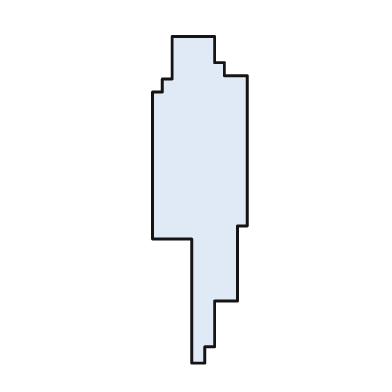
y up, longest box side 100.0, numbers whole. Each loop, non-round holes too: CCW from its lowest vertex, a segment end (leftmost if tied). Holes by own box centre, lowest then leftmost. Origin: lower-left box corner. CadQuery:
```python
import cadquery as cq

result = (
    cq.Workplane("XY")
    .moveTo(12.0, 0.0)
    .lineTo(16.0, 0.0)
    .lineTo(16.0, 5.0)
    .lineTo(19.0, 5.0)
    .lineTo(19.0, 19.0)
    .lineTo(26.0, 19.0)
    .lineTo(26.0, 42.0)
    .lineTo(29.0, 42.0)
    .lineTo(29.0, 88.0)
    .lineTo(22.0, 88.0)
    .lineTo(22.0, 92.0)
    .lineTo(19.0, 92.0)
    .lineTo(19.0, 100.0)
    .lineTo(6.0, 100.0)
    .lineTo(6.0, 87.0)
    .lineTo(3.0, 87.0)
    .lineTo(3.0, 83.0)
    .lineTo(0.0, 83.0)
    .lineTo(0.0, 38.0)
    .lineTo(12.0, 38.0)
    .close()
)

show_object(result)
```